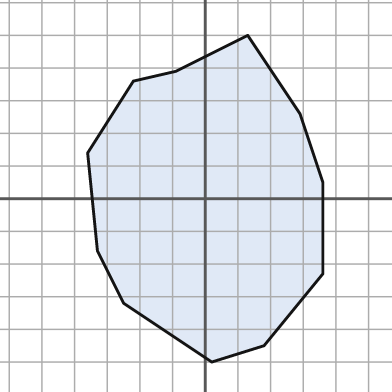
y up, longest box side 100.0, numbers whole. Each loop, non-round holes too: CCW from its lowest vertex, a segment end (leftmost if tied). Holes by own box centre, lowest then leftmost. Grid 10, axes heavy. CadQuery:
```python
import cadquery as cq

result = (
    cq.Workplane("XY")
    .moveTo(2.0, -50.0)
    .lineTo(18.0, -45.0)
    .lineTo(36.0, -23.0)
    .lineTo(36.0, 5.0)
    .lineTo(29.0, 26.0)
    .lineTo(13.0, 50.0)
    .lineTo(-9.0, 39.0)
    .lineTo(-22.0, 36.0)
    .lineTo(-36.0, 14.0)
    .lineTo(-33.0, -16.0)
    .lineTo(-25.0, -32.0)
    .close()
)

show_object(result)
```